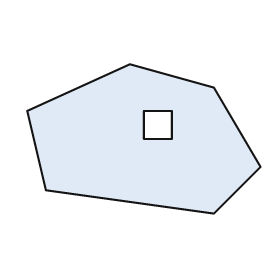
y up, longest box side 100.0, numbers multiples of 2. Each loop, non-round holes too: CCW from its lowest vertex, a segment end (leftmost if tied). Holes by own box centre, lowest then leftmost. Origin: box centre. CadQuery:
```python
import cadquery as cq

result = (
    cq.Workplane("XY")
    .moveTo(30.0, -32.0)
    .lineTo(50.0, -12.0)
    .lineTo(30.0, 22.0)
    .lineTo(-6.0, 32.0)
    .lineTo(-50.0, 12.0)
    .lineTo(-42.0, -22.0)
    .close()
    .moveTo(0.0, 0.0)
    .lineTo(12.0, 0.0)
    .lineTo(12.0, 12.0)
    .lineTo(0.0, 12.0)
    .close()
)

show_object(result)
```